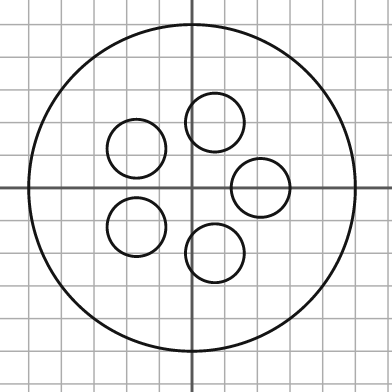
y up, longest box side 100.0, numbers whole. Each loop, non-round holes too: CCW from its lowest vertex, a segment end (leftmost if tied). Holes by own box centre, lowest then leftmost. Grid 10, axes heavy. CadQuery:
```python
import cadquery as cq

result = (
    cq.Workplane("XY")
    .moveTo(0.0, 0.0)
    .circle(50.0)
    .moveTo(7.0, -20.0)
    .circle(9.0)
    .moveTo(-17.0, -12.0)
    .circle(9.0)
    .moveTo(21.0, 0.0)
    .circle(9.0)
    .moveTo(-17.0, 12.0)
    .circle(9.0)
    .moveTo(7.0, 20.0)
    .circle(9.0)
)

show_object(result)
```